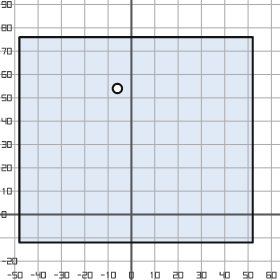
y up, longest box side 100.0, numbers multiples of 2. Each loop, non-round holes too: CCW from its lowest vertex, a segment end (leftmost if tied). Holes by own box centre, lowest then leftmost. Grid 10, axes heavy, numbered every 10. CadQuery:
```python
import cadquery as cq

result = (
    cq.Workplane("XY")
    .moveTo(-48.0, -12.0)
    .lineTo(52.0, -12.0)
    .lineTo(52.0, 76.0)
    .lineTo(-48.0, 76.0)
    .close()
    .moveTo(-6.0, 54.0)
    .circle(2.0)
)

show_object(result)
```